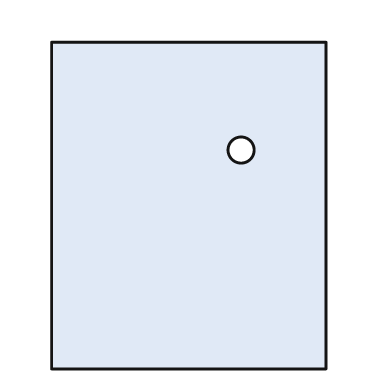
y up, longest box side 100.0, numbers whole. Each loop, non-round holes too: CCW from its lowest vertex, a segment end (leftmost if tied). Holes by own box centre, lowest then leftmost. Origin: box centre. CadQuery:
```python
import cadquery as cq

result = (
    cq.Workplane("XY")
    .moveTo(-42.0, -50.0)
    .lineTo(42.0, -50.0)
    .lineTo(42.0, 50.0)
    .lineTo(-42.0, 50.0)
    .close()
    .moveTo(16.0, 17.0)
    .circle(4.0)
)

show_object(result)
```